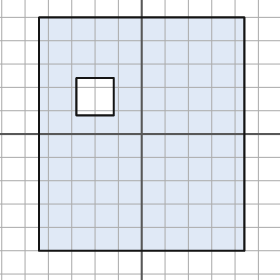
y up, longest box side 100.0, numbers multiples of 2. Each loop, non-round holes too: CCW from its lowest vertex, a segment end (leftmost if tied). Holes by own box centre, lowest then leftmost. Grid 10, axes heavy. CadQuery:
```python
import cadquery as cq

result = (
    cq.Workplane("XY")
    .moveTo(-44.0, -50.0)
    .lineTo(44.0, -50.0)
    .lineTo(44.0, 50.0)
    .lineTo(-44.0, 50.0)
    .close()
    .moveTo(-28.0, 8.0)
    .lineTo(-12.0, 8.0)
    .lineTo(-12.0, 24.0)
    .lineTo(-28.0, 24.0)
    .close()
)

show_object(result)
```